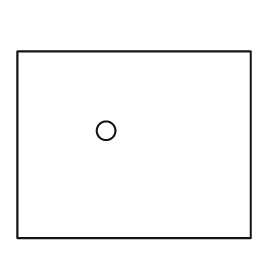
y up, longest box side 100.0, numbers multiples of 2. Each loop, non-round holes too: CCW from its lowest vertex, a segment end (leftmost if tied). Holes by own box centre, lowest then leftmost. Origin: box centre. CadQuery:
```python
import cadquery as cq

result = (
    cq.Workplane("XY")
    .moveTo(-50.0, -40.0)
    .lineTo(50.0, -40.0)
    .lineTo(50.0, 40.0)
    .lineTo(-50.0, 40.0)
    .close()
    .moveTo(-12.0, 6.0)
    .circle(4.0)
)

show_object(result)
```